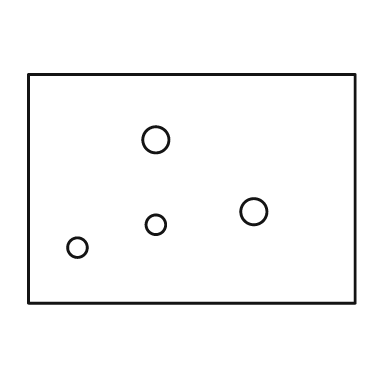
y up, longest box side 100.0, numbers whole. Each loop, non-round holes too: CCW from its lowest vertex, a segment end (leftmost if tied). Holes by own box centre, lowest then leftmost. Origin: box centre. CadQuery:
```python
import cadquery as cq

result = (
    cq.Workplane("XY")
    .moveTo(-50.0, -35.0)
    .lineTo(50.0, -35.0)
    .lineTo(50.0, 35.0)
    .lineTo(-50.0, 35.0)
    .close()
    .moveTo(-35.0, -18.0)
    .circle(3.0)
    .moveTo(-11.0, -11.0)
    .circle(3.0)
    .moveTo(19.0, -7.0)
    .circle(4.0)
    .moveTo(-11.0, 15.0)
    .circle(4.0)
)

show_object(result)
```